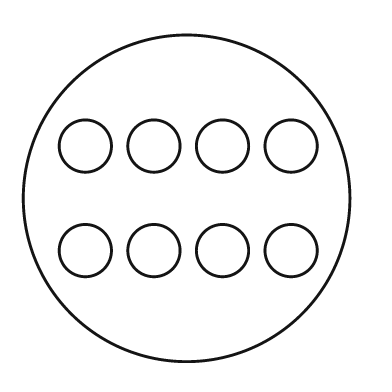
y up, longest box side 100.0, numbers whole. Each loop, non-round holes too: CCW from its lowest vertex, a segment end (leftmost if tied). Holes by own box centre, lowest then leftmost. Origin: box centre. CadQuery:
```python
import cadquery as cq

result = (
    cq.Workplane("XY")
    .moveTo(0.0, 0.0)
    .circle(50.0)
    .moveTo(-31.0, -16.0)
    .circle(8.0)
    .moveTo(-10.0, -16.0)
    .circle(8.0)
    .moveTo(11.0, -16.0)
    .circle(8.0)
    .moveTo(32.0, -16.0)
    .circle(8.0)
    .moveTo(-31.0, 16.0)
    .circle(8.0)
    .moveTo(-10.0, 16.0)
    .circle(8.0)
    .moveTo(11.0, 16.0)
    .circle(8.0)
    .moveTo(32.0, 16.0)
    .circle(8.0)
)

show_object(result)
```